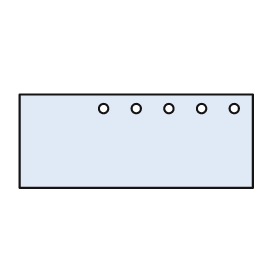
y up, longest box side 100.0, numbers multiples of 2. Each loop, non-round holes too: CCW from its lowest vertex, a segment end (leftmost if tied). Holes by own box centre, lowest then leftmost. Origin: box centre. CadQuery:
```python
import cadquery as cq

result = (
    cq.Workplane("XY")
    .moveTo(-50.0, -20.0)
    .lineTo(50.0, -20.0)
    .lineTo(50.0, 20.0)
    .lineTo(-50.0, 20.0)
    .close()
    .moveTo(-14.0, 14.0)
    .circle(2.0)
    .moveTo(0.0, 14.0)
    .circle(2.0)
    .moveTo(14.0, 14.0)
    .circle(2.0)
    .moveTo(28.0, 14.0)
    .circle(2.0)
    .moveTo(42.0, 14.0)
    .circle(2.0)
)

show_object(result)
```